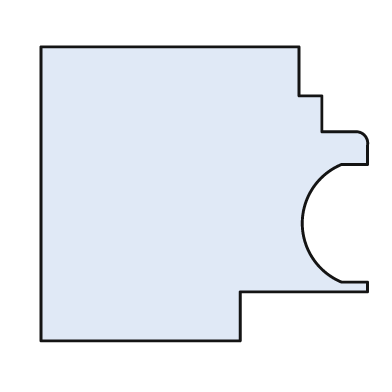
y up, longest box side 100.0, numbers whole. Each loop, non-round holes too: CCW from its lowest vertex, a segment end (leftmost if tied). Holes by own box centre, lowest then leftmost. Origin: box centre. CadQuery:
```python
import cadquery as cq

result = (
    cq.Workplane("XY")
    .moveTo(-50.0, -45.0)
    .lineTo(11.0, -45.0)
    .lineTo(11.0, -30.0)
    .lineTo(50.0, -30.0)
    .lineTo(50.0, -27.0)
    .lineTo(42.0, -27.0)
    .threePointArc((30.0, -9.0), (42.0, 9.0))
    .lineTo(50.0, 9.0)
    .lineTo(50.0, 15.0)
    .threePointArc((49.0, 18.0), (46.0, 19.0))
    .lineTo(36.0, 19.0)
    .lineTo(36.0, 30.0)
    .lineTo(29.0, 30.0)
    .lineTo(29.0, 45.0)
    .lineTo(-50.0, 45.0)
    .close()
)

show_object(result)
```